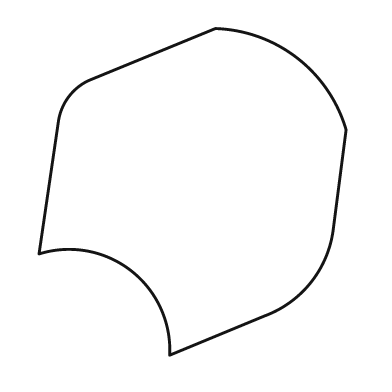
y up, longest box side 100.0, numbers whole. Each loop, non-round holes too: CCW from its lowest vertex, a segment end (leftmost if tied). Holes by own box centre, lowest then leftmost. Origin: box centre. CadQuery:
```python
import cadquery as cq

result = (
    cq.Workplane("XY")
    .moveTo(-7.0, -50.0)
    .lineTo(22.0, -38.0)
    .threePointArc((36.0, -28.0), (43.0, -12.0))
    .lineTo(47.0, 19.0)
    .threePointArc((32.0, 41.0), (7.0, 50.0))
    .lineTo(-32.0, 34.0)
    .threePointArc((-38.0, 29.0), (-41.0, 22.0))
    .lineTo(-47.0, -19.0)
    .threePointArc((-19.0, -24.0), (-7.0, -50.0))
    .close()
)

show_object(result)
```